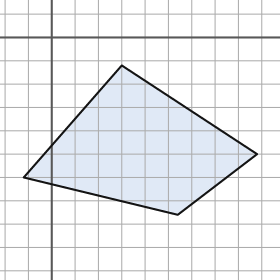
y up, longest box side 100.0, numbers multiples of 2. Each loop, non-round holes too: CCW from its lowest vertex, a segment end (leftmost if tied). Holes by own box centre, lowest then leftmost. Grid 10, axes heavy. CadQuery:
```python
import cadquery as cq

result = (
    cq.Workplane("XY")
    .moveTo(54.0, -76.0)
    .lineTo(88.0, -50.0)
    .lineTo(30.0, -12.0)
    .lineTo(-12.0, -60.0)
    .close()
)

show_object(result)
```